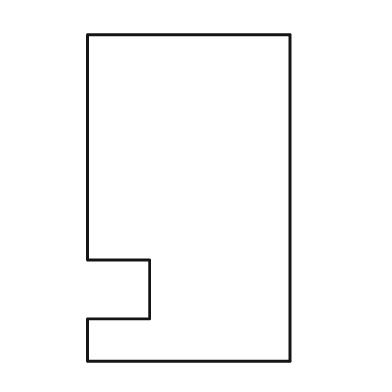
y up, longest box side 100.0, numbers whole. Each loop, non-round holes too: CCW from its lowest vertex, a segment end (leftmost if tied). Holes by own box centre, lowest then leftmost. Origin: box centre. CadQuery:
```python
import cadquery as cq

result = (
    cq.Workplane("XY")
    .moveTo(-31.0, -50.0)
    .lineTo(31.0, -50.0)
    .lineTo(31.0, 50.0)
    .lineTo(-31.0, 50.0)
    .lineTo(-31.0, -19.0)
    .lineTo(-12.0, -19.0)
    .lineTo(-12.0, -37.0)
    .lineTo(-31.0, -37.0)
    .close()
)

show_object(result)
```